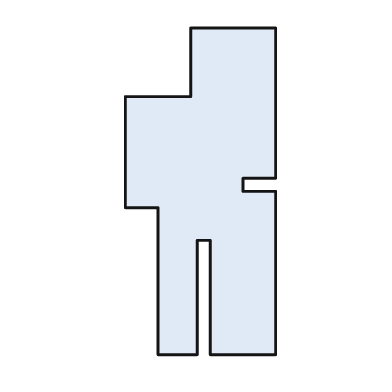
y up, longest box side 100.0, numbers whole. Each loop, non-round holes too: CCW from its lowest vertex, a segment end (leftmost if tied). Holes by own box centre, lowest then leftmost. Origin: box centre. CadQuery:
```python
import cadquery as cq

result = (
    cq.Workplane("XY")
    .moveTo(-13.0, -50.0)
    .lineTo(-1.0, -50.0)
    .lineTo(-1.0, -15.0)
    .lineTo(3.0, -15.0)
    .lineTo(3.0, -50.0)
    .lineTo(23.0, -50.0)
    .lineTo(23.0, 0.0)
    .lineTo(13.0, 0.0)
    .lineTo(13.0, 4.0)
    .lineTo(23.0, 4.0)
    .lineTo(23.0, 50.0)
    .lineTo(-3.0, 50.0)
    .lineTo(-3.0, 29.0)
    .lineTo(-23.0, 29.0)
    .lineTo(-23.0, -5.0)
    .lineTo(-13.0, -5.0)
    .close()
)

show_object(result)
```